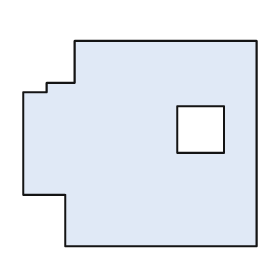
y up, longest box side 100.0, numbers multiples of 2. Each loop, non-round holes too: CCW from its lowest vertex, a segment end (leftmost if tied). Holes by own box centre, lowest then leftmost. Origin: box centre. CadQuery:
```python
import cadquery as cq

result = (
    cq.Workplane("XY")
    .moveTo(-32.0, -44.0)
    .lineTo(50.0, -44.0)
    .lineTo(50.0, 44.0)
    .lineTo(-28.0, 44.0)
    .lineTo(-28.0, 26.0)
    .lineTo(-40.0, 26.0)
    .lineTo(-40.0, 22.0)
    .lineTo(-50.0, 22.0)
    .lineTo(-50.0, -22.0)
    .lineTo(-32.0, -22.0)
    .close()
    .moveTo(16.0, -4.0)
    .lineTo(36.0, -4.0)
    .lineTo(36.0, 16.0)
    .lineTo(16.0, 16.0)
    .close()
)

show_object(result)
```